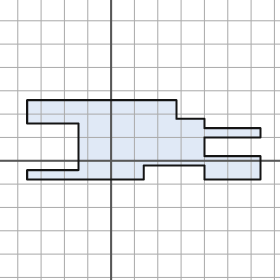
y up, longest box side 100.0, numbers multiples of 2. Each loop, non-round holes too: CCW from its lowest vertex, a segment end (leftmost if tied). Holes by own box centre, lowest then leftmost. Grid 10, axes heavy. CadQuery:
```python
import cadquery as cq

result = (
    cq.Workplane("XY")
    .moveTo(-36.0, -8.0)
    .lineTo(14.0, -8.0)
    .lineTo(14.0, -2.0)
    .lineTo(40.0, -2.0)
    .lineTo(40.0, -8.0)
    .lineTo(64.0, -8.0)
    .lineTo(64.0, 2.0)
    .lineTo(40.0, 2.0)
    .lineTo(40.0, 10.0)
    .lineTo(64.0, 10.0)
    .lineTo(64.0, 14.0)
    .lineTo(40.0, 14.0)
    .lineTo(40.0, 18.0)
    .lineTo(28.0, 18.0)
    .lineTo(28.0, 26.0)
    .lineTo(-36.0, 26.0)
    .lineTo(-36.0, 16.0)
    .lineTo(-14.0, 16.0)
    .lineTo(-14.0, -4.0)
    .lineTo(-36.0, -4.0)
    .close()
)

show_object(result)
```